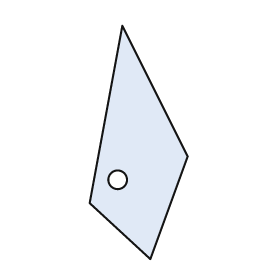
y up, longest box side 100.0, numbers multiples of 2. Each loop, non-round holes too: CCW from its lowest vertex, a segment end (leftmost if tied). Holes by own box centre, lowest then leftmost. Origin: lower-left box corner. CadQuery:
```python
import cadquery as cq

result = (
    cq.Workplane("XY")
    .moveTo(26.0, 0.0)
    .lineTo(42.0, 44.0)
    .lineTo(14.0, 100.0)
    .lineTo(0.0, 24.0)
    .close()
    .moveTo(12.0, 34.0)
    .circle(4.0)
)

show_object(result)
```